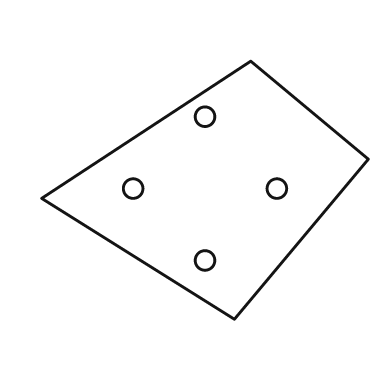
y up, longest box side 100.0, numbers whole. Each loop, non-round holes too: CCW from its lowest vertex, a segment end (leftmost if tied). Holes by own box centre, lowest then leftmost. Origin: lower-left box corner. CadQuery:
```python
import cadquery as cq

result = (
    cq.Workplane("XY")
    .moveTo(59.0, 0.0)
    .lineTo(100.0, 49.0)
    .lineTo(64.0, 79.0)
    .lineTo(0.0, 37.0)
    .close()
    .moveTo(50.0, 18.0)
    .circle(3.0)
    .moveTo(28.0, 40.0)
    .circle(3.0)
    .moveTo(72.0, 40.0)
    .circle(3.0)
    .moveTo(50.0, 62.0)
    .circle(3.0)
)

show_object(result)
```